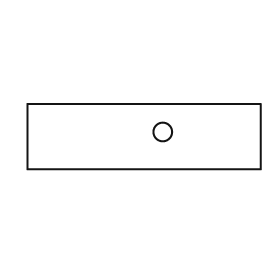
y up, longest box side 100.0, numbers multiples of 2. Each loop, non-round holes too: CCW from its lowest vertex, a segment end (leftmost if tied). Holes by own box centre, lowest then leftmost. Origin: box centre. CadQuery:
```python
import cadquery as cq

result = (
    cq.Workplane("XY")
    .moveTo(-50.0, -14.0)
    .lineTo(50.0, -14.0)
    .lineTo(50.0, 14.0)
    .lineTo(-50.0, 14.0)
    .close()
    .moveTo(8.0, 2.0)
    .circle(4.0)
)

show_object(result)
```